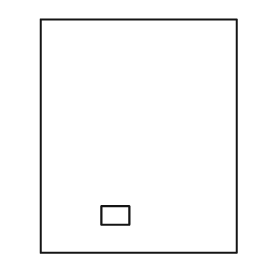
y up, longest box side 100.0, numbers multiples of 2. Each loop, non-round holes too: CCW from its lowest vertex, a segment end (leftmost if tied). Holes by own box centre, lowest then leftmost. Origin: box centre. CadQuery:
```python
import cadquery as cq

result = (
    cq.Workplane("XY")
    .moveTo(-42.0, -50.0)
    .lineTo(42.0, -50.0)
    .lineTo(42.0, 50.0)
    .lineTo(-42.0, 50.0)
    .close()
    .moveTo(-16.0, -38.0)
    .lineTo(-4.0, -38.0)
    .lineTo(-4.0, -30.0)
    .lineTo(-16.0, -30.0)
    .close()
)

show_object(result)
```